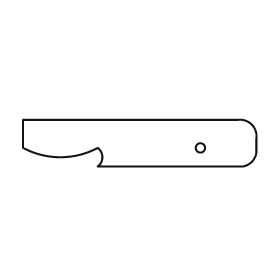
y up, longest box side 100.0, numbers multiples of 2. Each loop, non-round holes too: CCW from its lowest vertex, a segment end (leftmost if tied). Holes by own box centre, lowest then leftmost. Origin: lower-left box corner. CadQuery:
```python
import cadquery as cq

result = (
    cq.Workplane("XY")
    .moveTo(32.0, 0.0)
    .lineTo(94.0, 0.0)
    .threePointArc((98.0, 2.0), (100.0, 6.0))
    .lineTo(100.0, 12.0)
    .threePointArc((98.0, 18.0), (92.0, 20.0))
    .lineTo(0.0, 20.0)
    .lineTo(0.0, 8.0)
    .threePointArc((16.0, 4.0), (32.0, 8.0))
    .threePointArc((34.0, 4.0), (32.0, 0.0))
    .close()
    .moveTo(76.0, 8.0)
    .circle(2.0)
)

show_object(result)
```